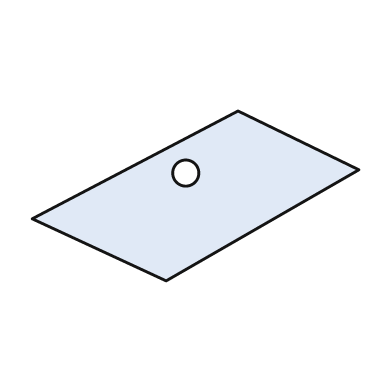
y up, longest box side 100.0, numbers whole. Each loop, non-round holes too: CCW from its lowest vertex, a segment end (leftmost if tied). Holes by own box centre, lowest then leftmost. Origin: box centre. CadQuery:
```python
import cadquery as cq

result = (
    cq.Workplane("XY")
    .moveTo(-9.0, -26.0)
    .lineTo(50.0, 8.0)
    .lineTo(13.0, 26.0)
    .lineTo(-50.0, -7.0)
    .close()
    .moveTo(-3.0, 7.0)
    .circle(4.0)
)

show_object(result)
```